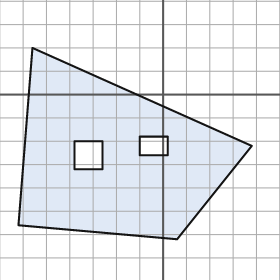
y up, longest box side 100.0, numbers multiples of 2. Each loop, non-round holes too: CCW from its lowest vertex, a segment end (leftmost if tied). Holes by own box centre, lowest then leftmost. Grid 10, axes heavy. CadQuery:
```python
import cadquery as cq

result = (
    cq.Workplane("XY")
    .moveTo(6.0, -62.0)
    .lineTo(38.0, -22.0)
    .lineTo(-56.0, 20.0)
    .lineTo(-62.0, -56.0)
    .close()
    .moveTo(-38.0, -32.0)
    .lineTo(-26.0, -32.0)
    .lineTo(-26.0, -20.0)
    .lineTo(-38.0, -20.0)
    .close()
    .moveTo(-10.0, -26.0)
    .lineTo(2.0, -26.0)
    .lineTo(2.0, -18.0)
    .lineTo(-10.0, -18.0)
    .close()
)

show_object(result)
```